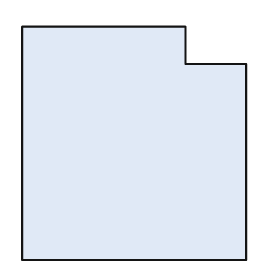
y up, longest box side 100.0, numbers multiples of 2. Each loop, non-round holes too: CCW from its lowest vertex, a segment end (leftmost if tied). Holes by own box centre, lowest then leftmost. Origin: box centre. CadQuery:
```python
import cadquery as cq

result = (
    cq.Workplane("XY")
    .moveTo(-48.0, -50.0)
    .lineTo(48.0, -50.0)
    .lineTo(48.0, 34.0)
    .lineTo(22.0, 34.0)
    .lineTo(22.0, 50.0)
    .lineTo(-48.0, 50.0)
    .close()
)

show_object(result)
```